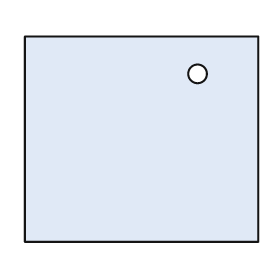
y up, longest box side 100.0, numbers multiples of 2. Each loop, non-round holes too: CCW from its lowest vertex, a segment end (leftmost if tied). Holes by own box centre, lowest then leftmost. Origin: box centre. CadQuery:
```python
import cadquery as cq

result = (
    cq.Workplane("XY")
    .moveTo(-50.0, -44.0)
    .lineTo(50.0, -44.0)
    .lineTo(50.0, 44.0)
    .lineTo(-50.0, 44.0)
    .close()
    .moveTo(24.0, 28.0)
    .circle(4.0)
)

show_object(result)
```